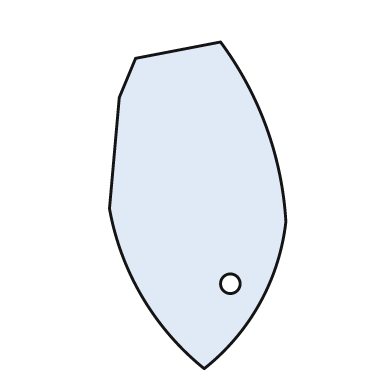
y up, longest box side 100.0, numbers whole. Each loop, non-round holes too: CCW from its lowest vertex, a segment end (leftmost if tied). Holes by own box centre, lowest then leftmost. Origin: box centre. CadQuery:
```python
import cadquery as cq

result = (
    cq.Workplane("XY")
    .moveTo(2.0, -50.0)
    .threePointArc((19.0, -30.0), (27.0, -5.0))
    .threePointArc((21.0, 24.0), (7.0, 50.0))
    .lineTo(-19.0, 45.0)
    .lineTo(-24.0, 33.0)
    .lineTo(-27.0, -1.0)
    .threePointArc((-17.0, -28.0), (2.0, -50.0))
    .close()
    .moveTo(10.0, -24.0)
    .circle(3.0)
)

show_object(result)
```